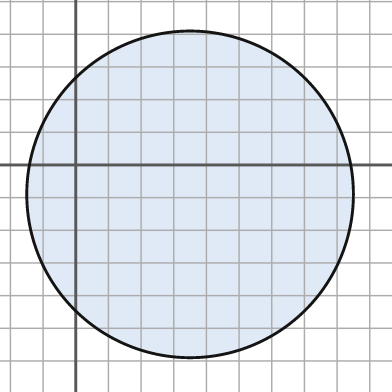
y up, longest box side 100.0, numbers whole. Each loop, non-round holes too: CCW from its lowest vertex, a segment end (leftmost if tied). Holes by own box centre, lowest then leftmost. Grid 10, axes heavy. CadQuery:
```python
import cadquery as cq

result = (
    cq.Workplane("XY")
    .moveTo(35.0, -9.0)
    .circle(50.0)
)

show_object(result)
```